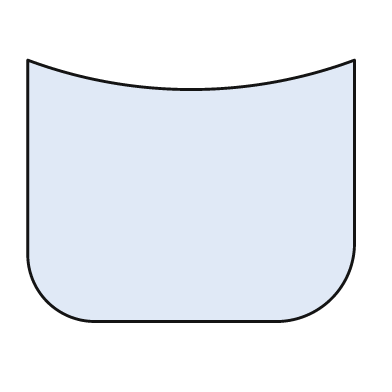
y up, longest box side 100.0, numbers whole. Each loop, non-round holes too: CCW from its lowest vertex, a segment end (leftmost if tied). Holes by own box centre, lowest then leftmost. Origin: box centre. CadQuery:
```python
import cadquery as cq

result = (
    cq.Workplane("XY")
    .moveTo(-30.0, -40.0)
    .lineTo(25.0, -40.0)
    .threePointArc((43.0, -33.0), (50.0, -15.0))
    .lineTo(50.0, 40.0)
    .threePointArc((0.0, 31.0), (-50.0, 40.0))
    .lineTo(-50.0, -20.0)
    .threePointArc((-44.0, -34.0), (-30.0, -40.0))
    .close()
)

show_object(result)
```